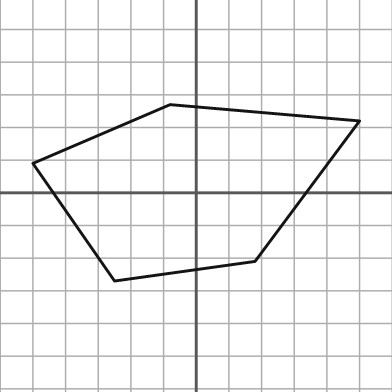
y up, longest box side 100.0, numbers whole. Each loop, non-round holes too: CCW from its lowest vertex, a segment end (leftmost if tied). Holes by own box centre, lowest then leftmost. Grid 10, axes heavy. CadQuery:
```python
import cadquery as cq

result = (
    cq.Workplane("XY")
    .moveTo(-25.0, -27.0)
    .lineTo(18.0, -21.0)
    .lineTo(50.0, 22.0)
    .lineTo(-8.0, 27.0)
    .lineTo(-50.0, 9.0)
    .close()
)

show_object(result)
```